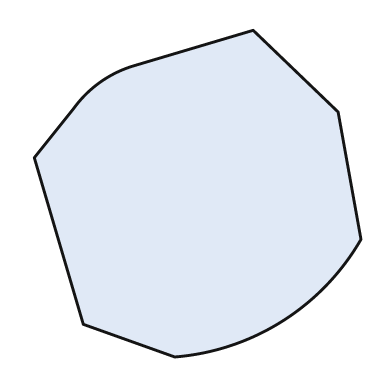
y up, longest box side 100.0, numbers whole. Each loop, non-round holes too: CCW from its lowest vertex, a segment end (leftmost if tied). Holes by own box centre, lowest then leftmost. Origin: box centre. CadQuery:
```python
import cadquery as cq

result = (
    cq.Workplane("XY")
    .moveTo(-7.0, -50.0)
    .threePointArc((26.0, -39.0), (50.0, -14.0))
    .lineTo(43.0, 25.0)
    .lineTo(17.0, 50.0)
    .lineTo(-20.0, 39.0)
    .threePointArc((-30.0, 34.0), (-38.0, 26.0))
    .lineTo(-50.0, 11.0)
    .lineTo(-35.0, -40.0)
    .close()
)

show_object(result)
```